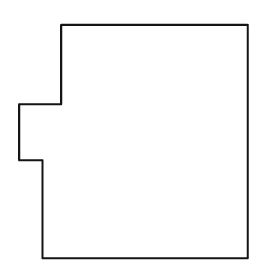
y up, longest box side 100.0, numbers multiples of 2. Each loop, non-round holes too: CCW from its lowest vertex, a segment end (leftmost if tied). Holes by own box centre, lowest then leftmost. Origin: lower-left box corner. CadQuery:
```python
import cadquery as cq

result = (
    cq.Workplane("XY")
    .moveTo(10.0, 0.0)
    .lineTo(98.0, 0.0)
    .lineTo(98.0, 100.0)
    .lineTo(18.0, 100.0)
    .lineTo(18.0, 66.0)
    .lineTo(0.0, 66.0)
    .lineTo(0.0, 42.0)
    .lineTo(10.0, 42.0)
    .close()
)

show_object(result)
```